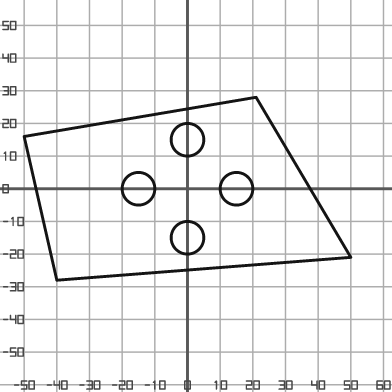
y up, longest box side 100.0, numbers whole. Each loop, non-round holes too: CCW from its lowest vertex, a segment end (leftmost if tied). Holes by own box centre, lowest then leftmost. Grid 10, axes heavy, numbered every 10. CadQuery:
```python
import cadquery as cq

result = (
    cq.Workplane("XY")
    .moveTo(-40.0, -28.0)
    .lineTo(50.0, -21.0)
    .lineTo(21.0, 28.0)
    .lineTo(-50.0, 16.0)
    .close()
    .moveTo(0.0, -15.0)
    .circle(5.0)
    .moveTo(-15.0, 0.0)
    .circle(5.0)
    .moveTo(15.0, 0.0)
    .circle(5.0)
    .moveTo(0.0, 15.0)
    .circle(5.0)
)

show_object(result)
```